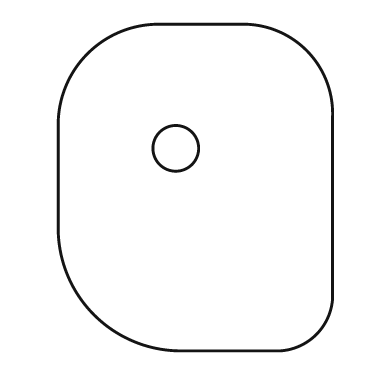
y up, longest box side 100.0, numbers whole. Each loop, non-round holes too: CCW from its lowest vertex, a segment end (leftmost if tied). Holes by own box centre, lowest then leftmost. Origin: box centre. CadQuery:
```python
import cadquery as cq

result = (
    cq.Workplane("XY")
    .moveTo(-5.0, -50.0)
    .lineTo(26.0, -50.0)
    .threePointArc((37.0, -45.0), (42.0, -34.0))
    .lineTo(42.0, 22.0)
    .threePointArc((34.0, 42.0), (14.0, 50.0))
    .lineTo(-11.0, 50.0)
    .threePointArc((-33.0, 41.0), (-42.0, 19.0))
    .lineTo(-42.0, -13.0)
    .threePointArc((-31.0, -39.0), (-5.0, -50.0))
    .close()
    .moveTo(-6.0, 12.0)
    .circle(7.0)
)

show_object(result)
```